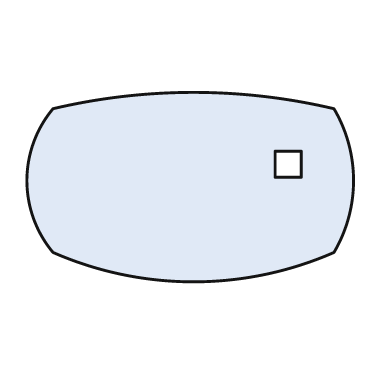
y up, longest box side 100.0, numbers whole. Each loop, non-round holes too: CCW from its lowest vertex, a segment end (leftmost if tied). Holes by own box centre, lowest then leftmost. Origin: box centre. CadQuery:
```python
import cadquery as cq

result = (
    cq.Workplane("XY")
    .moveTo(-42.0, -20.0)
    .threePointArc((1.0, -29.0), (44.0, -20.0))
    .threePointArc((50.0, 2.0), (44.0, 24.0))
    .threePointArc((1.0, 29.0), (-42.0, 24.0))
    .threePointArc((-50.0, 2.0), (-42.0, -20.0))
    .close()
    .moveTo(26.0, 3.0)
    .lineTo(34.0, 3.0)
    .lineTo(34.0, 11.0)
    .lineTo(26.0, 11.0)
    .close()
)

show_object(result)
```